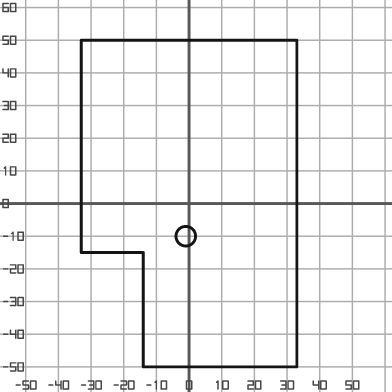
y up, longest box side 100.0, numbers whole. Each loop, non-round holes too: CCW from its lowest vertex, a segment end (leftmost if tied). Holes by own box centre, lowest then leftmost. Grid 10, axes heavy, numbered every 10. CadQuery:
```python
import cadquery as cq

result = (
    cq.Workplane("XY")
    .moveTo(-14.0, -50.0)
    .lineTo(33.0, -50.0)
    .lineTo(33.0, 50.0)
    .lineTo(-33.0, 50.0)
    .lineTo(-33.0, -15.0)
    .lineTo(-14.0, -15.0)
    .close()
    .moveTo(-1.0, -10.0)
    .circle(3.0)
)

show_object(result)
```